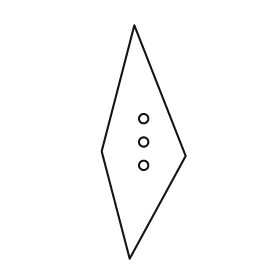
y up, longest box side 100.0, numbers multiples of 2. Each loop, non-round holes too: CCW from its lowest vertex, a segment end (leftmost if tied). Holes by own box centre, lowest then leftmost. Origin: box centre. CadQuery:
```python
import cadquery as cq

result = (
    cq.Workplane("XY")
    .moveTo(-6.0, -50.0)
    .lineTo(18.0, -6.0)
    .lineTo(-4.0, 50.0)
    .lineTo(-18.0, -4.0)
    .close()
    .moveTo(0.0, -10.0)
    .circle(2.0)
    .moveTo(0.0, 0.0)
    .circle(2.0)
    .moveTo(0.0, 10.0)
    .circle(2.0)
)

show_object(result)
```